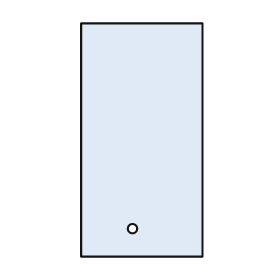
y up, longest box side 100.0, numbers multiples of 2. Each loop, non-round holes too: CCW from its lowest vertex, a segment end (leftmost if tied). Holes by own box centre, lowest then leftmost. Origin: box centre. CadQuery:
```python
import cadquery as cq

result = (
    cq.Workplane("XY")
    .moveTo(-26.0, -50.0)
    .lineTo(26.0, -50.0)
    .lineTo(26.0, 50.0)
    .lineTo(-26.0, 50.0)
    .close()
    .moveTo(-4.0, -38.0)
    .circle(2.0)
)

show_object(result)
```